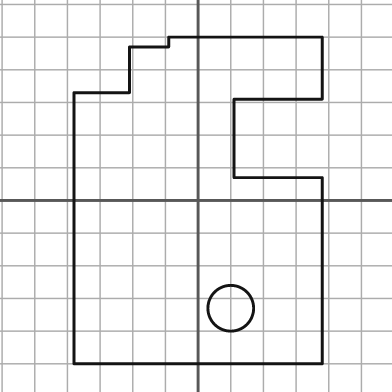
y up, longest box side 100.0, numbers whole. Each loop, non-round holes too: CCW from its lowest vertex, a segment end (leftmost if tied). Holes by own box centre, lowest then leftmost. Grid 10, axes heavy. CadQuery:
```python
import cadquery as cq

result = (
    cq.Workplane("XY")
    .moveTo(-38.0, -50.0)
    .lineTo(38.0, -50.0)
    .lineTo(38.0, 7.0)
    .lineTo(11.0, 7.0)
    .lineTo(11.0, 31.0)
    .lineTo(38.0, 31.0)
    .lineTo(38.0, 50.0)
    .lineTo(-9.0, 50.0)
    .lineTo(-9.0, 47.0)
    .lineTo(-21.0, 47.0)
    .lineTo(-21.0, 33.0)
    .lineTo(-38.0, 33.0)
    .close()
    .moveTo(10.0, -33.0)
    .circle(7.0)
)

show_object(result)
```